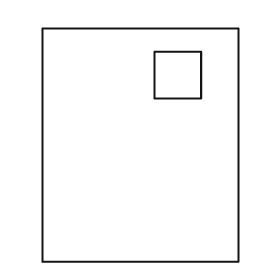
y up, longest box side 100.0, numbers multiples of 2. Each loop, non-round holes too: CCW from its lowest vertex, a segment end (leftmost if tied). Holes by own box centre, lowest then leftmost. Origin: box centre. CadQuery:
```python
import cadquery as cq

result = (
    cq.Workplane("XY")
    .moveTo(-42.0, -50.0)
    .lineTo(42.0, -50.0)
    .lineTo(42.0, 50.0)
    .lineTo(-42.0, 50.0)
    .close()
    .moveTo(6.0, 20.0)
    .lineTo(26.0, 20.0)
    .lineTo(26.0, 40.0)
    .lineTo(6.0, 40.0)
    .close()
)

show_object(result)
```